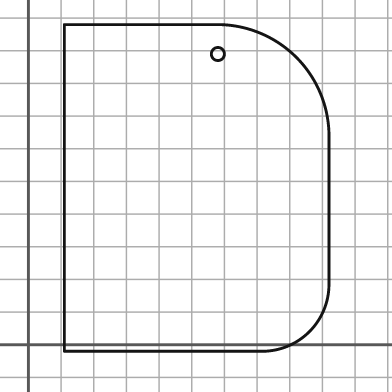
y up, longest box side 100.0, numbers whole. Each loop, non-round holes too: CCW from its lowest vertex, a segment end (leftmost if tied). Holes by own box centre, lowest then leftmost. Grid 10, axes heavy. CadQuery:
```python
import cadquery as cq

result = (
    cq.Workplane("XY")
    .moveTo(11.0, -2.0)
    .lineTo(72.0, -2.0)
    .threePointArc((86.0, 4.0), (92.0, 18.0))
    .lineTo(92.0, 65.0)
    .threePointArc((82.0, 88.0), (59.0, 98.0))
    .lineTo(11.0, 98.0)
    .close()
    .moveTo(58.0, 89.0)
    .circle(2.0)
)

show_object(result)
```